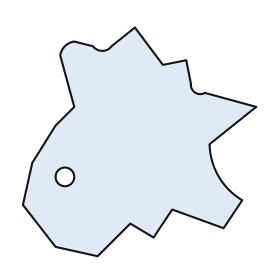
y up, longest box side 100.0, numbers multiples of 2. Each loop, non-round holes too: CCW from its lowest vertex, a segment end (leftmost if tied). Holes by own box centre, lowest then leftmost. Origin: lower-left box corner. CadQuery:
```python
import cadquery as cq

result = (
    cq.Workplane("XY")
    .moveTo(32.0, 0.0)
    .lineTo(46.0, 14.0)
    .lineTo(56.0, 8.0)
    .lineTo(64.0, 20.0)
    .lineTo(86.0, 12.0)
    .lineTo(94.0, 24.0)
    .threePointArc((84.0, 34.0), (80.0, 48.0))
    .lineTo(100.0, 64.0)
    .lineTo(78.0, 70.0)
    .threePointArc((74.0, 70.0), (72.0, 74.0))
    .lineTo(70.0, 84.0)
    .lineTo(60.0, 82.0)
    .lineTo(48.0, 98.0)
    .lineTo(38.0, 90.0)
    .threePointArc((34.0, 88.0), (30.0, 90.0))
    .lineTo(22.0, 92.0)
    .threePointArc((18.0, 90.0), (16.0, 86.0))
    .lineTo(22.0, 64.0)
    .lineTo(14.0, 56.0)
    .lineTo(4.0, 40.0)
    .lineTo(0.0, 22.0)
    .lineTo(14.0, 4.0)
    .close()
    .moveTo(18.0, 34.0)
    .circle(4.0)
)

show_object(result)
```